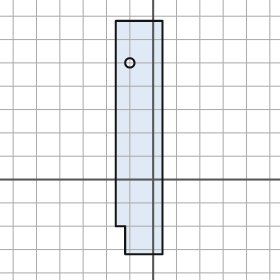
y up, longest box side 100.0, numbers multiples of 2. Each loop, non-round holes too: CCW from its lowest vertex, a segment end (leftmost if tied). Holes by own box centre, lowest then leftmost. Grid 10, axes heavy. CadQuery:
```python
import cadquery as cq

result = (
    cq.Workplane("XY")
    .moveTo(-12.0, -32.0)
    .lineTo(4.0, -32.0)
    .lineTo(4.0, 68.0)
    .lineTo(-16.0, 68.0)
    .lineTo(-16.0, -20.0)
    .lineTo(-12.0, -20.0)
    .close()
    .moveTo(-10.0, 50.0)
    .circle(2.0)
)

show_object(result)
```